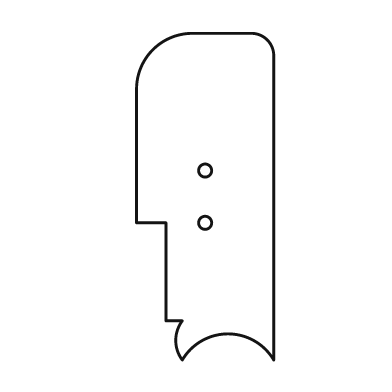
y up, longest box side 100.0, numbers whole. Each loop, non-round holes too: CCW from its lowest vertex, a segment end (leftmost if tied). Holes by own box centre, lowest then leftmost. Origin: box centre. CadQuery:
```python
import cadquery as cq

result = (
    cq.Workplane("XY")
    .moveTo(-7.0, -50.0)
    .threePointArc((7.0, -42.0), (21.0, -50.0))
    .lineTo(21.0, 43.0)
    .threePointArc((19.0, 48.0), (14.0, 50.0))
    .lineTo(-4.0, 50.0)
    .threePointArc((-16.0, 45.0), (-21.0, 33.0))
    .lineTo(-21.0, -8.0)
    .lineTo(-12.0, -8.0)
    .lineTo(-12.0, -38.0)
    .lineTo(-7.0, -38.0)
    .threePointArc((-9.0, -44.0), (-7.0, -50.0))
    .close()
    .moveTo(0.0, -8.0)
    .circle(2.0)
    .moveTo(0.0, 8.0)
    .circle(2.0)
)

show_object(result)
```